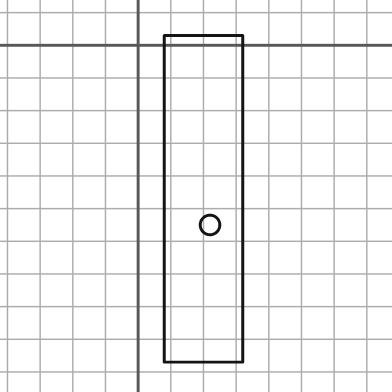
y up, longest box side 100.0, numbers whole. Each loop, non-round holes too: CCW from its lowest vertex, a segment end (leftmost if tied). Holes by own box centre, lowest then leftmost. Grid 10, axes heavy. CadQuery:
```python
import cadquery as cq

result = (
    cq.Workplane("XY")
    .moveTo(8.0, -97.0)
    .lineTo(32.0, -97.0)
    .lineTo(32.0, 3.0)
    .lineTo(8.0, 3.0)
    .close()
    .moveTo(22.0, -55.0)
    .circle(3.0)
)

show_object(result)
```